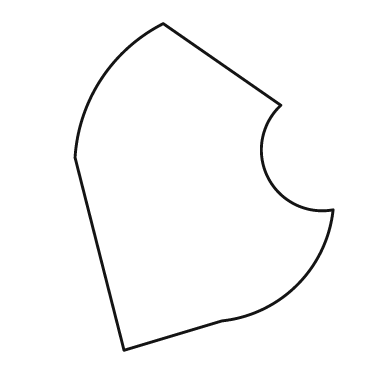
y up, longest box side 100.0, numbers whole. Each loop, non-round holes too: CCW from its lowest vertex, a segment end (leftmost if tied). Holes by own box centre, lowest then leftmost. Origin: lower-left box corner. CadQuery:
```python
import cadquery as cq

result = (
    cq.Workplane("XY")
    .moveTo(15.0, 0.0)
    .lineTo(45.0, 9.0)
    .threePointArc((68.0, 20.0), (79.0, 43.0))
    .threePointArc((59.0, 53.0), (63.0, 75.0))
    .lineTo(27.0, 100.0)
    .threePointArc((8.0, 83.0), (0.0, 59.0))
    .close()
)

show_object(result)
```